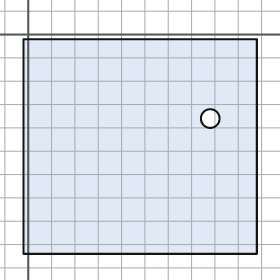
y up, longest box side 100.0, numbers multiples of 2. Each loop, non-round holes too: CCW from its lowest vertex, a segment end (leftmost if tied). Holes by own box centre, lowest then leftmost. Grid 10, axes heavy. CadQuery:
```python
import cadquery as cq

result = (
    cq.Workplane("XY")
    .moveTo(-2.0, -94.0)
    .lineTo(98.0, -94.0)
    .lineTo(98.0, -2.0)
    .lineTo(-2.0, -2.0)
    .close()
    .moveTo(78.0, -36.0)
    .circle(4.0)
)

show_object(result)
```